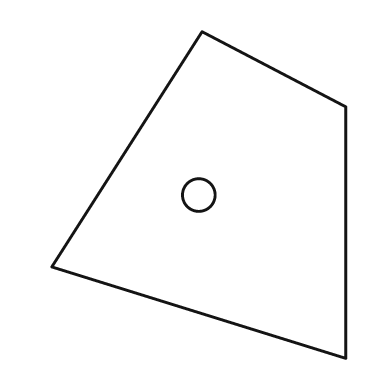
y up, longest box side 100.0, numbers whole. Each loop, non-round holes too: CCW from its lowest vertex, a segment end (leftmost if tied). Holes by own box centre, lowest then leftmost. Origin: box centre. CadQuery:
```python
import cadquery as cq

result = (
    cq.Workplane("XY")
    .moveTo(45.0, -50.0)
    .lineTo(45.0, 27.0)
    .lineTo(1.0, 50.0)
    .lineTo(-45.0, -22.0)
    .close()
    .moveTo(0.0, 0.0)
    .circle(5.0)
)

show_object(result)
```